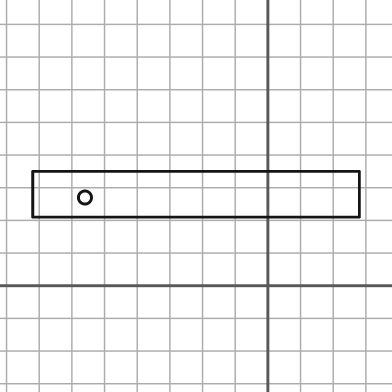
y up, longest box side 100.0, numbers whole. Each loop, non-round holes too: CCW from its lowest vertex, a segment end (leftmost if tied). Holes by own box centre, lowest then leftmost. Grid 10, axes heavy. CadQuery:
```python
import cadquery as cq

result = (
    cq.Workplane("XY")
    .moveTo(-72.0, 21.0)
    .lineTo(28.0, 21.0)
    .lineTo(28.0, 35.0)
    .lineTo(-72.0, 35.0)
    .close()
    .moveTo(-56.0, 27.0)
    .circle(2.0)
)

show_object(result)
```